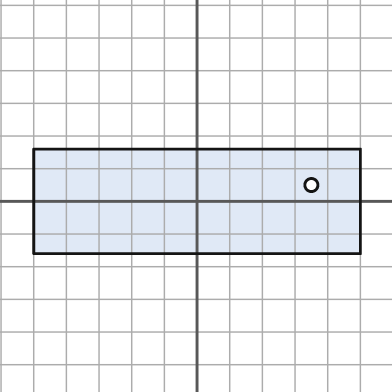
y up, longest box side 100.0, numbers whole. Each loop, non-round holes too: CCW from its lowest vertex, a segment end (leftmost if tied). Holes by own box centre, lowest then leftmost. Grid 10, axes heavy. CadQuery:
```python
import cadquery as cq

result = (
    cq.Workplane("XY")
    .moveTo(-50.0, -16.0)
    .lineTo(50.0, -16.0)
    .lineTo(50.0, 16.0)
    .lineTo(-50.0, 16.0)
    .close()
    .moveTo(35.0, 5.0)
    .circle(2.0)
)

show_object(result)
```